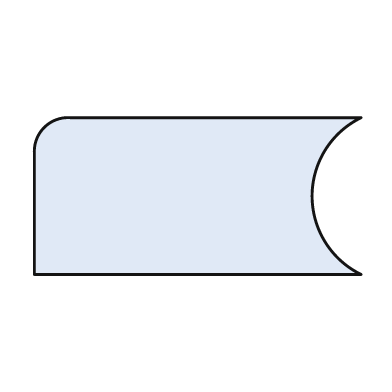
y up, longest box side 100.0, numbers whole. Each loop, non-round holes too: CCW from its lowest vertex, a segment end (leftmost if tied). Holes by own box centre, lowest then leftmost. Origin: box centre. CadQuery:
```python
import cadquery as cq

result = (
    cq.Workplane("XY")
    .moveTo(-50.0, -24.0)
    .lineTo(50.0, -24.0)
    .threePointArc((35.0, 0.0), (50.0, 24.0))
    .lineTo(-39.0, 24.0)
    .threePointArc((-47.0, 21.0), (-50.0, 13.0))
    .close()
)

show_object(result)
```